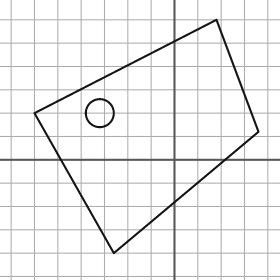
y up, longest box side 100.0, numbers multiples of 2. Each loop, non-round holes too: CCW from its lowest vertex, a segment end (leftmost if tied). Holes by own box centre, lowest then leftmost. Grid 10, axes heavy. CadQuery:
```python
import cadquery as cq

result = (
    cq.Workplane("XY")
    .moveTo(-26.0, -40.0)
    .lineTo(36.0, 12.0)
    .lineTo(18.0, 60.0)
    .lineTo(-60.0, 20.0)
    .close()
    .moveTo(-32.0, 20.0)
    .circle(6.0)
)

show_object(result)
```